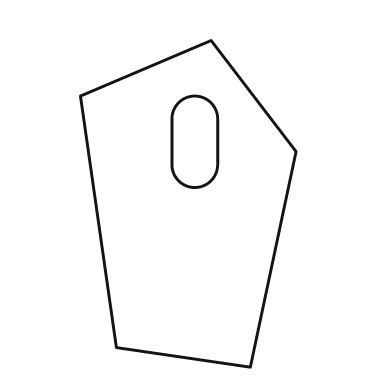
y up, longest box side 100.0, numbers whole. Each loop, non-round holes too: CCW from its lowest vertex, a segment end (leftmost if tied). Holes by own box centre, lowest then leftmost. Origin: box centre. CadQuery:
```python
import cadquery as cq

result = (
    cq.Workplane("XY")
    .moveTo(19.0, -50.0)
    .lineTo(33.0, 16.0)
    .lineTo(7.0, 50.0)
    .lineTo(-33.0, 33.0)
    .lineTo(-22.0, -44.0)
    .close()
    .moveTo(-5.0, 12.0)
    .threePointArc((2.0, 5.0), (9.0, 12.0))
    .lineTo(9.0, 26.0)
    .threePointArc((2.0, 33.0), (-5.0, 26.0))
    .close()
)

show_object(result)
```